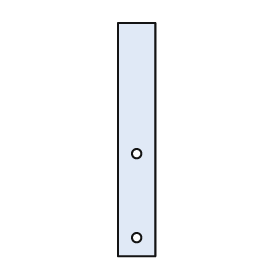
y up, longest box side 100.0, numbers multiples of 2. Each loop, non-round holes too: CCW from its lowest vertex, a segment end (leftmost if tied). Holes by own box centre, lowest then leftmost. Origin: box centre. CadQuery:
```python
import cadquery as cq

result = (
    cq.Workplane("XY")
    .moveTo(-8.0, -50.0)
    .lineTo(8.0, -50.0)
    .lineTo(8.0, 50.0)
    .lineTo(-8.0, 50.0)
    .close()
    .moveTo(0.0, -42.0)
    .circle(2.0)
    .moveTo(0.0, -6.0)
    .circle(2.0)
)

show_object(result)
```